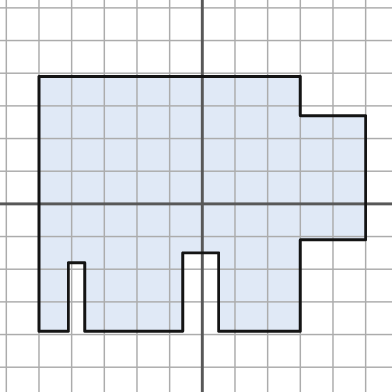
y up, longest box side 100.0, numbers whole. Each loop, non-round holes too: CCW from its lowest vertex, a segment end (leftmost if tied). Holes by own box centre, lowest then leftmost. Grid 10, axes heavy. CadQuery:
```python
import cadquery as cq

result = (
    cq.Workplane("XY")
    .moveTo(-50.0, -39.0)
    .lineTo(-41.0, -39.0)
    .lineTo(-41.0, -18.0)
    .lineTo(-36.0, -18.0)
    .lineTo(-36.0, -39.0)
    .lineTo(-6.0, -39.0)
    .lineTo(-6.0, -15.0)
    .lineTo(5.0, -15.0)
    .lineTo(5.0, -39.0)
    .lineTo(30.0, -39.0)
    .lineTo(30.0, -11.0)
    .lineTo(50.0, -11.0)
    .lineTo(50.0, 27.0)
    .lineTo(30.0, 27.0)
    .lineTo(30.0, 39.0)
    .lineTo(-50.0, 39.0)
    .close()
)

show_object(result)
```